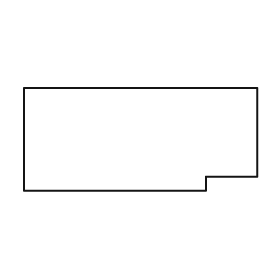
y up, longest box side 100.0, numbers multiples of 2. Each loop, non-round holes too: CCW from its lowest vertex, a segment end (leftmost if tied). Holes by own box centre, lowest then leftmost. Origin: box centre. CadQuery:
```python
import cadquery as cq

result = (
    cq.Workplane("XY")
    .moveTo(-50.0, -22.0)
    .lineTo(28.0, -22.0)
    .lineTo(28.0, -16.0)
    .lineTo(50.0, -16.0)
    .lineTo(50.0, 22.0)
    .lineTo(-50.0, 22.0)
    .close()
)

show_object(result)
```